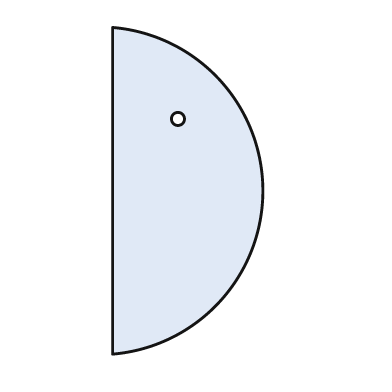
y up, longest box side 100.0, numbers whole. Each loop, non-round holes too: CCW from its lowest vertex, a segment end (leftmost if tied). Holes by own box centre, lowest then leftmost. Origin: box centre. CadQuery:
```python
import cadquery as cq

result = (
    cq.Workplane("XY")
    .moveTo(-23.0, -50.0)
    .threePointArc((23.0, 0.0), (-23.0, 50.0))
    .close()
    .moveTo(-3.0, 22.0)
    .circle(2.0)
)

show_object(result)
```